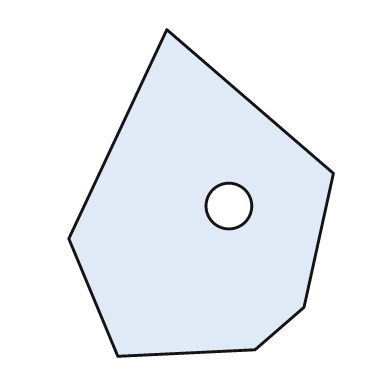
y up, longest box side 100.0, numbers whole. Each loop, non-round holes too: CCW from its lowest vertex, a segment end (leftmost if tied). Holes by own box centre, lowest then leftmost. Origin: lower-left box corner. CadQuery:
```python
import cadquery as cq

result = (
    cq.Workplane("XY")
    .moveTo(15.0, 0.0)
    .lineTo(57.0, 2.0)
    .lineTo(72.0, 15.0)
    .lineTo(81.0, 56.0)
    .lineTo(30.0, 100.0)
    .lineTo(0.0, 36.0)
    .close()
    .moveTo(49.0, 46.0)
    .circle(7.0)
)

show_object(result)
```